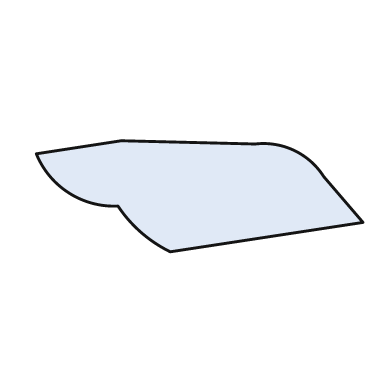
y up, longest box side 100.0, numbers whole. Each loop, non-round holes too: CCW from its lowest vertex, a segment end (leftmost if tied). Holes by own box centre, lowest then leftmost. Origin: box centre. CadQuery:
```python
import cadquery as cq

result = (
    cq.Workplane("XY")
    .moveTo(-9.0, -17.0)
    .lineTo(50.0, -8.0)
    .lineTo(38.0, 6.0)
    .threePointArc((29.0, 14.0), (17.0, 16.0))
    .lineTo(-24.0, 17.0)
    .lineTo(-50.0, 13.0)
    .threePointArc((-40.0, 1.0), (-25.0, -3.0))
    .threePointArc((-18.0, -11.0), (-9.0, -17.0))
    .close()
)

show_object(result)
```